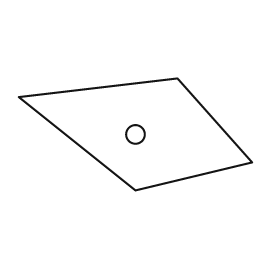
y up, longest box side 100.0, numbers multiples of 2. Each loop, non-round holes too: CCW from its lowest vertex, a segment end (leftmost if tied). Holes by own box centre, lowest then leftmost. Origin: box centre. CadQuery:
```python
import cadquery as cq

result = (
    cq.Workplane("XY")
    .moveTo(0.0, -24.0)
    .lineTo(50.0, -12.0)
    .lineTo(18.0, 24.0)
    .lineTo(-50.0, 16.0)
    .close()
    .moveTo(0.0, 0.0)
    .circle(4.0)
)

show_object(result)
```